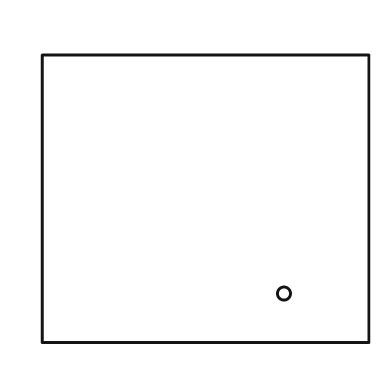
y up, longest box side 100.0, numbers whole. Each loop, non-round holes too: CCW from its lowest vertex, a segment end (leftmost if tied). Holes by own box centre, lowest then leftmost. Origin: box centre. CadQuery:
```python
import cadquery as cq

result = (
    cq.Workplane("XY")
    .moveTo(-50.0, -44.0)
    .lineTo(50.0, -44.0)
    .lineTo(50.0, 44.0)
    .lineTo(-50.0, 44.0)
    .close()
    .moveTo(24.0, -29.0)
    .circle(2.0)
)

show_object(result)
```